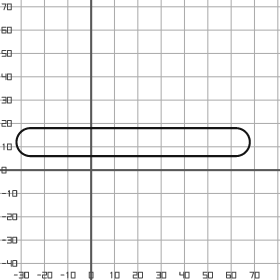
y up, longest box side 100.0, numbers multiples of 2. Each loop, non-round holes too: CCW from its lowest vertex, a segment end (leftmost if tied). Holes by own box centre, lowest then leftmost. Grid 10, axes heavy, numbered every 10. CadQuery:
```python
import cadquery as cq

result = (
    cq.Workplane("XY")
    .moveTo(-26.0, 6.0)
    .lineTo(62.0, 6.0)
    .threePointArc((68.0, 12.0), (62.0, 18.0))
    .lineTo(-26.0, 18.0)
    .threePointArc((-32.0, 12.0), (-26.0, 6.0))
    .close()
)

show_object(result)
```